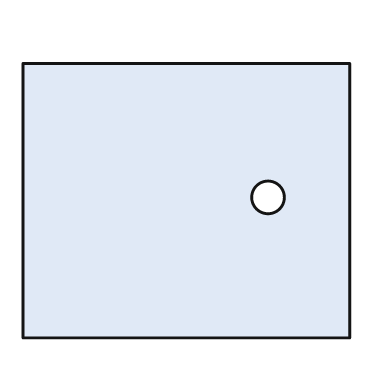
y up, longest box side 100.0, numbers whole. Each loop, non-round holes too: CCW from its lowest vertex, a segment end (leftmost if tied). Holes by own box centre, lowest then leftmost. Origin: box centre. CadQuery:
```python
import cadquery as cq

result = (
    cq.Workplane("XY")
    .moveTo(-50.0, -42.0)
    .lineTo(50.0, -42.0)
    .lineTo(50.0, 42.0)
    .lineTo(-50.0, 42.0)
    .close()
    .moveTo(25.0, 1.0)
    .circle(5.0)
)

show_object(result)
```